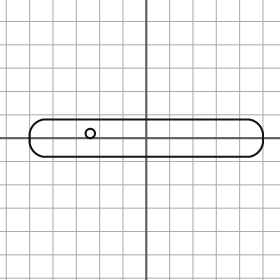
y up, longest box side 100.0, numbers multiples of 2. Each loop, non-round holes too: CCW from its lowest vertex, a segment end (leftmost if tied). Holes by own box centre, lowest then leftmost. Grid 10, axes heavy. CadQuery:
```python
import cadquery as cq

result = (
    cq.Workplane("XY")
    .moveTo(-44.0, -8.0)
    .lineTo(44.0, -8.0)
    .threePointArc((48.0, -6.0), (50.0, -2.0))
    .lineTo(50.0, 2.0)
    .threePointArc((48.0, 6.0), (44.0, 8.0))
    .lineTo(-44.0, 8.0)
    .threePointArc((-48.0, 6.0), (-50.0, 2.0))
    .lineTo(-50.0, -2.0)
    .threePointArc((-48.0, -6.0), (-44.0, -8.0))
    .close()
    .moveTo(-24.0, 2.0)
    .circle(2.0)
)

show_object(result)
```